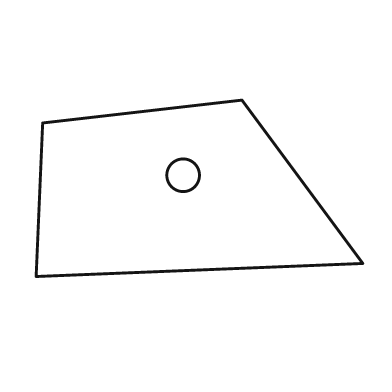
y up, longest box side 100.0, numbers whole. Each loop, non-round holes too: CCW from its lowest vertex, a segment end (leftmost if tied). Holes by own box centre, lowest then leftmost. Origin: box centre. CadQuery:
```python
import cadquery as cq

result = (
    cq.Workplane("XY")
    .moveTo(-50.0, -27.0)
    .lineTo(50.0, -23.0)
    .lineTo(13.0, 27.0)
    .lineTo(-48.0, 20.0)
    .close()
    .moveTo(-5.0, 4.0)
    .circle(5.0)
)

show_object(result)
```